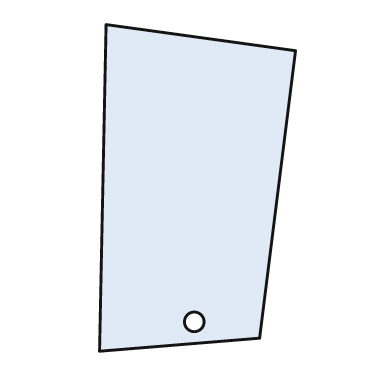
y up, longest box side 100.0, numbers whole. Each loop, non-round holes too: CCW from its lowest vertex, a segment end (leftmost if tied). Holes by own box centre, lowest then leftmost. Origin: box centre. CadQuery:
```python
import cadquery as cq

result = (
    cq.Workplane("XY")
    .moveTo(-30.0, -50.0)
    .lineTo(19.0, -46.0)
    .lineTo(30.0, 42.0)
    .lineTo(-28.0, 50.0)
    .close()
    .moveTo(-1.0, -41.0)
    .circle(3.0)
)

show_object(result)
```